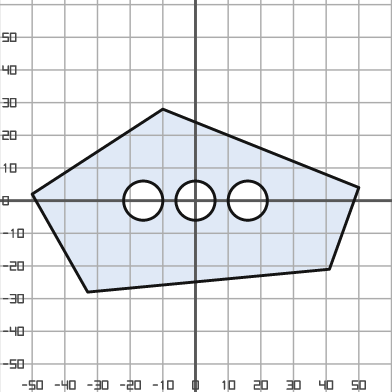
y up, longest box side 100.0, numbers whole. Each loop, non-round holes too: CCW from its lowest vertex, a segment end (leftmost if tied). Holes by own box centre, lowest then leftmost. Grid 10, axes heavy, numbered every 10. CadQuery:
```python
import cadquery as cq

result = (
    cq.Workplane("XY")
    .moveTo(-33.0, -28.0)
    .lineTo(41.0, -21.0)
    .lineTo(50.0, 4.0)
    .lineTo(-10.0, 28.0)
    .lineTo(-50.0, 2.0)
    .close()
    .moveTo(-16.0, 0.0)
    .circle(6.0)
    .moveTo(0.0, 0.0)
    .circle(6.0)
    .moveTo(16.0, 0.0)
    .circle(6.0)
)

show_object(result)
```